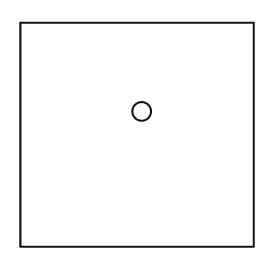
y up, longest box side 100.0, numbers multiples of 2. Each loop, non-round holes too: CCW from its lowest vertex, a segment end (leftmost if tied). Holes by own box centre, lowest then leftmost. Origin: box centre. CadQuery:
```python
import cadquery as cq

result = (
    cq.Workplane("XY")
    .moveTo(-50.0, -48.0)
    .lineTo(50.0, -48.0)
    .lineTo(50.0, 48.0)
    .lineTo(-50.0, 48.0)
    .close()
    .moveTo(2.0, 10.0)
    .circle(4.0)
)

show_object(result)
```